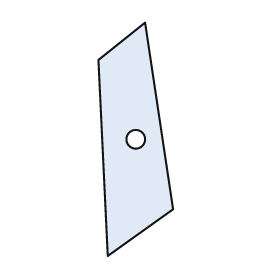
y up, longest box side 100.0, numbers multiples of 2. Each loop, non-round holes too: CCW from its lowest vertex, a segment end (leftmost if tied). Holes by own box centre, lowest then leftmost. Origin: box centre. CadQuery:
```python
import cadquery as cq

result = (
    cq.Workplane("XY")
    .moveTo(-12.0, -50.0)
    .lineTo(16.0, -30.0)
    .lineTo(4.0, 50.0)
    .lineTo(-16.0, 34.0)
    .close()
    .moveTo(0.0, 0.0)
    .circle(4.0)
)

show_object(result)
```